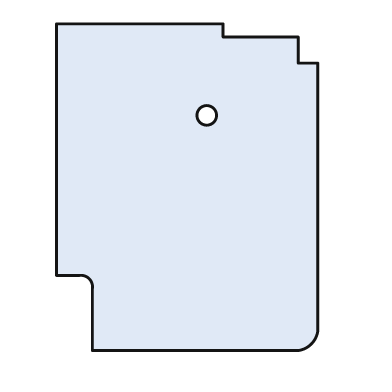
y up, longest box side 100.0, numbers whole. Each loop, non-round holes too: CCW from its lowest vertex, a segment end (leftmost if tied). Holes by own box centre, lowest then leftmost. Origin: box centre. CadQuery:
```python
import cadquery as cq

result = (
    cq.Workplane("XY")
    .moveTo(-29.0, -50.0)
    .lineTo(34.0, -50.0)
    .threePointArc((38.0, -48.0), (40.0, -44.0))
    .lineTo(40.0, 38.0)
    .lineTo(34.0, 38.0)
    .lineTo(34.0, 46.0)
    .lineTo(11.0, 46.0)
    .lineTo(11.0, 50.0)
    .lineTo(-40.0, 50.0)
    .lineTo(-40.0, -27.0)
    .lineTo(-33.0, -27.0)
    .threePointArc((-30.0, -28.0), (-29.0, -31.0))
    .close()
    .moveTo(6.0, 22.0)
    .circle(3.0)
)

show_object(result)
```